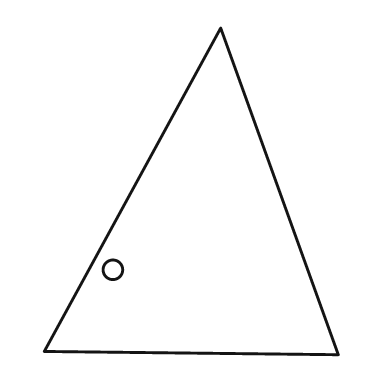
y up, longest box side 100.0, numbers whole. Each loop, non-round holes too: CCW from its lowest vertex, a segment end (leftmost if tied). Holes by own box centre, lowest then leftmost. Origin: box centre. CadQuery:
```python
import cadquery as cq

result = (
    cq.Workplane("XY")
    .moveTo(45.0, -50.0)
    .lineTo(9.0, 50.0)
    .lineTo(-45.0, -49.0)
    .close()
    .moveTo(-24.0, -24.0)
    .circle(3.0)
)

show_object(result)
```